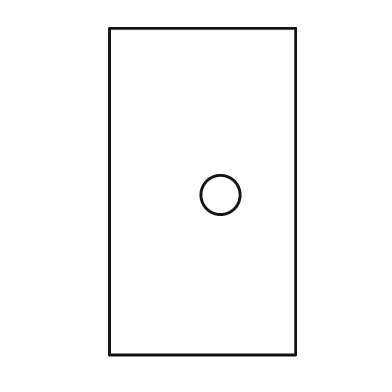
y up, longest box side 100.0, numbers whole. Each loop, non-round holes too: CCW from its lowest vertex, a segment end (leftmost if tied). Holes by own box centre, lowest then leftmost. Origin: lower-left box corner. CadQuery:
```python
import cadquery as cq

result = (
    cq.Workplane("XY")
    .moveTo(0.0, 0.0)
    .lineTo(57.0, 0.0)
    .lineTo(57.0, 100.0)
    .lineTo(0.0, 100.0)
    .close()
    .moveTo(34.0, 49.0)
    .circle(6.0)
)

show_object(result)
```